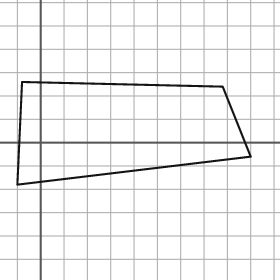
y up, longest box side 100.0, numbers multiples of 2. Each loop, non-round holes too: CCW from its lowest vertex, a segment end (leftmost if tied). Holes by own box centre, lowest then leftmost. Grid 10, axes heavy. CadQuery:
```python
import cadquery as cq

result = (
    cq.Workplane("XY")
    .moveTo(-10.0, -18.0)
    .lineTo(90.0, -6.0)
    .lineTo(78.0, 24.0)
    .lineTo(-8.0, 26.0)
    .close()
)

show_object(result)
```